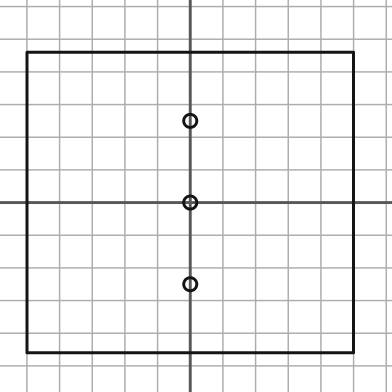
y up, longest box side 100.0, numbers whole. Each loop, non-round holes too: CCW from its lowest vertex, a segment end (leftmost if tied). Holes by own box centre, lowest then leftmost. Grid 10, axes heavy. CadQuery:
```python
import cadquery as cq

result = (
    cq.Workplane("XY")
    .moveTo(-50.0, -46.0)
    .lineTo(50.0, -46.0)
    .lineTo(50.0, 46.0)
    .lineTo(-50.0, 46.0)
    .close()
    .moveTo(0.0, -25.0)
    .circle(2.0)
    .moveTo(0.0, 0.0)
    .circle(2.0)
    .moveTo(0.0, 25.0)
    .circle(2.0)
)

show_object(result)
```